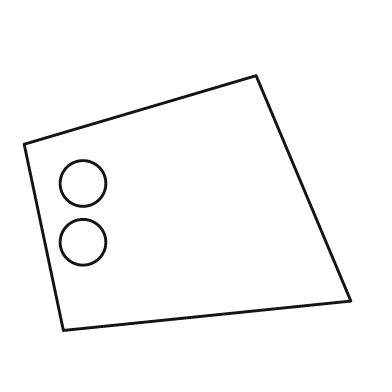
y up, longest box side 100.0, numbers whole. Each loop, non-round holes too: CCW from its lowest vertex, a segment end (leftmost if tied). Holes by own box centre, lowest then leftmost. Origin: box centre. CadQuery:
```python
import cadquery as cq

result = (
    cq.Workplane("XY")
    .moveTo(-38.0, -39.0)
    .lineTo(50.0, -30.0)
    .lineTo(21.0, 39.0)
    .lineTo(-50.0, 18.0)
    .close()
    .moveTo(-32.0, -12.0)
    .circle(7.0)
    .moveTo(-32.0, 6.0)
    .circle(7.0)
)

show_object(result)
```